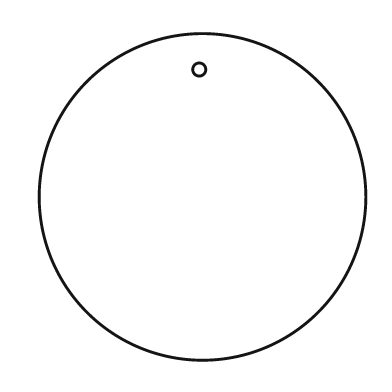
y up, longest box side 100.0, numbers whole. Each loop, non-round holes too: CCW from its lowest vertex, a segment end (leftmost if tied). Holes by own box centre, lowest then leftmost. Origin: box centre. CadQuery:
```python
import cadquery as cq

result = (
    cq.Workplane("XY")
    .moveTo(0.0, 0.0)
    .circle(50.0)
    .moveTo(-1.0, 39.0)
    .circle(2.0)
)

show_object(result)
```